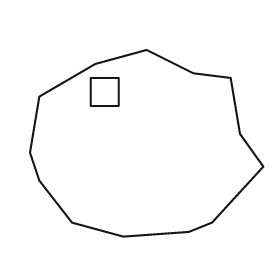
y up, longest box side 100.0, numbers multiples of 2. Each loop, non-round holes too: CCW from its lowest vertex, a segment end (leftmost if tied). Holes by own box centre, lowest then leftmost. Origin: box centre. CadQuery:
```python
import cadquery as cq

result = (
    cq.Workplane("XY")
    .moveTo(-10.0, -40.0)
    .lineTo(18.0, -38.0)
    .lineTo(28.0, -34.0)
    .lineTo(50.0, -10.0)
    .lineTo(40.0, 4.0)
    .lineTo(36.0, 28.0)
    .lineTo(20.0, 30.0)
    .lineTo(0.0, 40.0)
    .lineTo(-22.0, 34.0)
    .lineTo(-46.0, 20.0)
    .lineTo(-50.0, -4.0)
    .lineTo(-46.0, -16.0)
    .lineTo(-32.0, -34.0)
    .close()
    .moveTo(-24.0, 16.0)
    .lineTo(-12.0, 16.0)
    .lineTo(-12.0, 28.0)
    .lineTo(-24.0, 28.0)
    .close()
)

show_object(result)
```